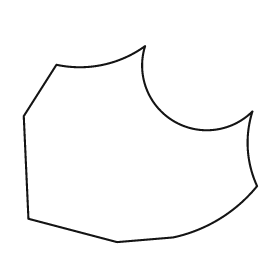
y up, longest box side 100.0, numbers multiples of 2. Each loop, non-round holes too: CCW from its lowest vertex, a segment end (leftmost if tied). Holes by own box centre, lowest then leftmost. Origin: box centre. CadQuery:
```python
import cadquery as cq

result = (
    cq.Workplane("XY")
    .moveTo(-10.0, -42.0)
    .lineTo(14.0, -40.0)
    .threePointArc((34.0, -32.0), (50.0, -18.0))
    .threePointArc((46.0, -2.0), (48.0, 14.0))
    .threePointArc((14.0, 10.0), (2.0, 42.0))
    .threePointArc((-16.0, 34.0), (-36.0, 34.0))
    .lineTo(-50.0, 12.0)
    .lineTo(-48.0, -32.0)
    .close()
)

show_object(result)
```